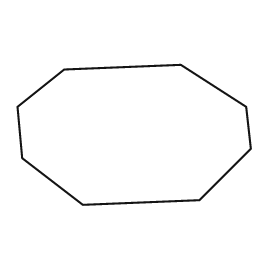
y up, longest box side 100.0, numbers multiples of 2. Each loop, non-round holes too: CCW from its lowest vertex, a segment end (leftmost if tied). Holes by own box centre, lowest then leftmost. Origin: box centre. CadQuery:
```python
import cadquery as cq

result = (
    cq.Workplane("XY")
    .moveTo(-22.0, -30.0)
    .lineTo(28.0, -28.0)
    .lineTo(50.0, -6.0)
    .lineTo(48.0, 12.0)
    .lineTo(20.0, 30.0)
    .lineTo(-30.0, 28.0)
    .lineTo(-50.0, 12.0)
    .lineTo(-48.0, -10.0)
    .close()
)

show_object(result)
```